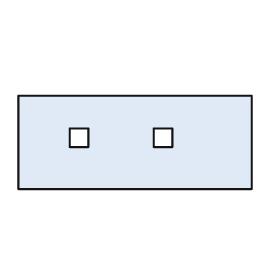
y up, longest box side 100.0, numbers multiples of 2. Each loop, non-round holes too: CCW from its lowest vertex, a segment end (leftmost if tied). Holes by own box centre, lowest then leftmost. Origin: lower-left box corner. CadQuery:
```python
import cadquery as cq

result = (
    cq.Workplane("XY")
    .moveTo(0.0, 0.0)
    .lineTo(100.0, 0.0)
    .lineTo(100.0, 40.0)
    .lineTo(0.0, 40.0)
    .close()
    .moveTo(22.0, 18.0)
    .lineTo(30.0, 18.0)
    .lineTo(30.0, 26.0)
    .lineTo(22.0, 26.0)
    .close()
    .moveTo(58.0, 18.0)
    .lineTo(66.0, 18.0)
    .lineTo(66.0, 26.0)
    .lineTo(58.0, 26.0)
    .close()
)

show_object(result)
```